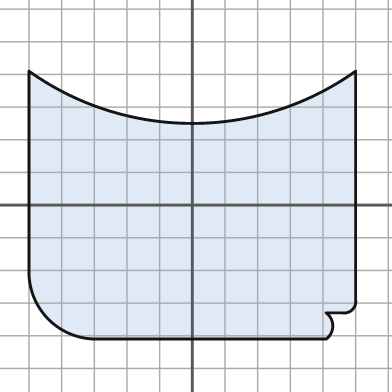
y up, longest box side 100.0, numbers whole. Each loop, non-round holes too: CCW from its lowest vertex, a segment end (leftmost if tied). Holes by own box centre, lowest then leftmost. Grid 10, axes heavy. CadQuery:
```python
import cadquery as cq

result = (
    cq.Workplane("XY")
    .moveTo(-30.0, -41.0)
    .lineTo(41.0, -41.0)
    .threePointArc((43.0, -37.0), (41.0, -33.0))
    .lineTo(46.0, -33.0)
    .threePointArc((49.0, -32.0), (50.0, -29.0))
    .lineTo(50.0, 41.0)
    .threePointArc((0.0, 25.0), (-50.0, 41.0))
    .lineTo(-50.0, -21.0)
    .threePointArc((-44.0, -35.0), (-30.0, -41.0))
    .close()
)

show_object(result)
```